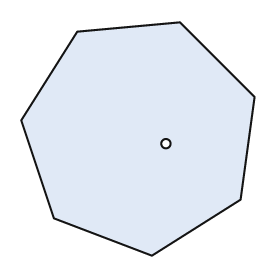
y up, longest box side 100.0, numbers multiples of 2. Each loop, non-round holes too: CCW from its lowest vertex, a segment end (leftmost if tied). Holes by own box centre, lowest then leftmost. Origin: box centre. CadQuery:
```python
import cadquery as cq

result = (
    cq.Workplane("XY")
    .moveTo(6.0, -50.0)
    .lineTo(44.0, -26.0)
    .lineTo(50.0, 18.0)
    .lineTo(18.0, 50.0)
    .lineTo(-26.0, 46.0)
    .lineTo(-50.0, 8.0)
    .lineTo(-36.0, -34.0)
    .close()
    .moveTo(12.0, -2.0)
    .circle(2.0)
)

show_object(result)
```